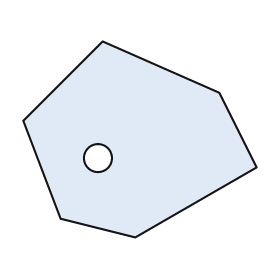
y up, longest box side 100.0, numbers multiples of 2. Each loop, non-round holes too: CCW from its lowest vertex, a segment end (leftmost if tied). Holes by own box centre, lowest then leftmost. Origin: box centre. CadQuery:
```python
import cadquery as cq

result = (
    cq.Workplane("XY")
    .moveTo(-2.0, -42.0)
    .lineTo(50.0, -12.0)
    .lineTo(34.0, 20.0)
    .lineTo(-16.0, 42.0)
    .lineTo(-50.0, 8.0)
    .lineTo(-34.0, -34.0)
    .close()
    .moveTo(-18.0, -8.0)
    .circle(6.0)
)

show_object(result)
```